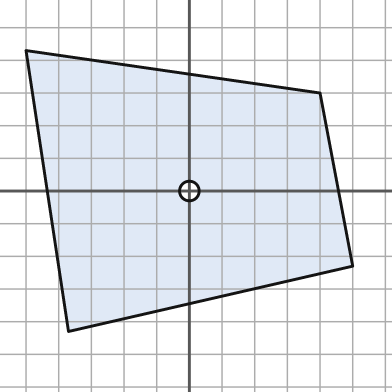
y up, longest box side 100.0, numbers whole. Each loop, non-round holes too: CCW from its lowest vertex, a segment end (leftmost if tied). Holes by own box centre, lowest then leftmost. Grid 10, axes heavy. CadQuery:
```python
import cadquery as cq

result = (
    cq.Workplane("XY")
    .moveTo(-37.0, -43.0)
    .lineTo(50.0, -23.0)
    .lineTo(40.0, 30.0)
    .lineTo(-50.0, 43.0)
    .close()
    .moveTo(0.0, 0.0)
    .circle(3.0)
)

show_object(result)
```